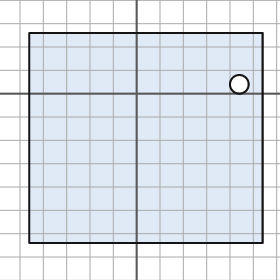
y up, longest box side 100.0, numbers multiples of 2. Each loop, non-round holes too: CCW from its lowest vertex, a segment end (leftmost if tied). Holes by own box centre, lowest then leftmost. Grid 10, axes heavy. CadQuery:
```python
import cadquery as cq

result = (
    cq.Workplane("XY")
    .moveTo(-46.0, -64.0)
    .lineTo(54.0, -64.0)
    .lineTo(54.0, 26.0)
    .lineTo(-46.0, 26.0)
    .close()
    .moveTo(44.0, 4.0)
    .circle(4.0)
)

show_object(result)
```